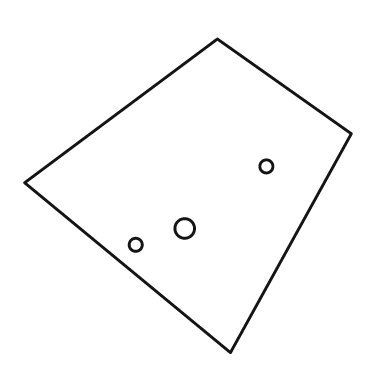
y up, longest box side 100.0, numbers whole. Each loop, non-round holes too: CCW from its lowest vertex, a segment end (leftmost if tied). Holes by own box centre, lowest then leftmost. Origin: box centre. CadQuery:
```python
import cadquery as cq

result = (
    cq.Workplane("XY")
    .moveTo(13.0, -48.0)
    .lineTo(50.0, 19.0)
    .lineTo(9.0, 48.0)
    .lineTo(-50.0, 4.0)
    .close()
    .moveTo(-16.0, -15.0)
    .circle(2.0)
    .moveTo(-1.0, -10.0)
    .circle(3.0)
    .moveTo(24.0, 9.0)
    .circle(2.0)
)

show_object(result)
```